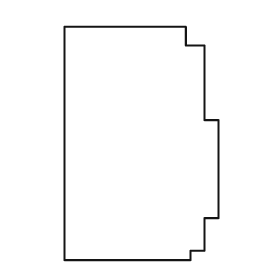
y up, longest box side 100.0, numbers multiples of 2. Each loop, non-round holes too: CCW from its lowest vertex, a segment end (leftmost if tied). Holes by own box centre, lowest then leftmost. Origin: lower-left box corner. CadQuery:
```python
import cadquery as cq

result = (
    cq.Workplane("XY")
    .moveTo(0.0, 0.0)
    .lineTo(54.0, 0.0)
    .lineTo(54.0, 4.0)
    .lineTo(60.0, 4.0)
    .lineTo(60.0, 18.0)
    .lineTo(66.0, 18.0)
    .lineTo(66.0, 60.0)
    .lineTo(60.0, 60.0)
    .lineTo(60.0, 92.0)
    .lineTo(52.0, 92.0)
    .lineTo(52.0, 100.0)
    .lineTo(0.0, 100.0)
    .close()
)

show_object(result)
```